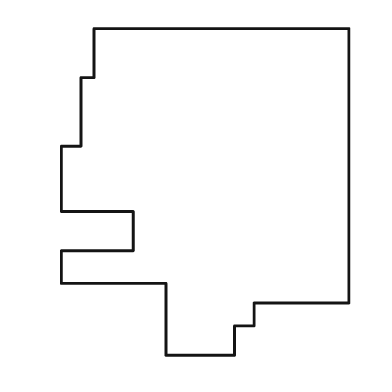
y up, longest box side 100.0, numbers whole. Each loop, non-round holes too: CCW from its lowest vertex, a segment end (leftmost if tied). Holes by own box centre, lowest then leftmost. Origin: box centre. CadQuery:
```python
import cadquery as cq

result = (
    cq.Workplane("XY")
    .moveTo(-12.0, -50.0)
    .lineTo(9.0, -50.0)
    .lineTo(9.0, -41.0)
    .lineTo(15.0, -41.0)
    .lineTo(15.0, -34.0)
    .lineTo(44.0, -34.0)
    .lineTo(44.0, 50.0)
    .lineTo(-34.0, 50.0)
    .lineTo(-34.0, 35.0)
    .lineTo(-38.0, 35.0)
    .lineTo(-38.0, 14.0)
    .lineTo(-44.0, 14.0)
    .lineTo(-44.0, -6.0)
    .lineTo(-22.0, -6.0)
    .lineTo(-22.0, -18.0)
    .lineTo(-44.0, -18.0)
    .lineTo(-44.0, -28.0)
    .lineTo(-12.0, -28.0)
    .close()
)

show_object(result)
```